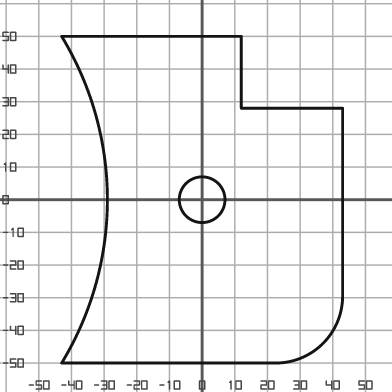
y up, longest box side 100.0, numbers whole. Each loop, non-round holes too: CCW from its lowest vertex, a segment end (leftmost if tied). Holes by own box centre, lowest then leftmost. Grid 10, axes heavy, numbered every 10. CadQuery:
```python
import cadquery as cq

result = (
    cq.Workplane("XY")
    .moveTo(-43.0, -50.0)
    .lineTo(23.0, -50.0)
    .threePointArc((37.0, -44.0), (43.0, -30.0))
    .lineTo(43.0, 28.0)
    .lineTo(12.0, 28.0)
    .lineTo(12.0, 50.0)
    .lineTo(-43.0, 50.0)
    .threePointArc((-29.0, 0.0), (-43.0, -50.0))
    .close()
    .moveTo(0.0, 0.0)
    .circle(7.0)
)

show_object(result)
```